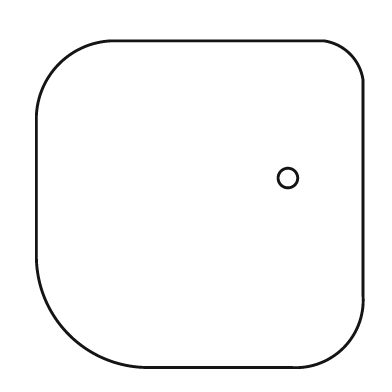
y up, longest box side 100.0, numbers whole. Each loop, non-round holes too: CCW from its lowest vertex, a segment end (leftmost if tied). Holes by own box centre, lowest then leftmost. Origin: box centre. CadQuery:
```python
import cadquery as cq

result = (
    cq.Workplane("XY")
    .moveTo(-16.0, -50.0)
    .lineTo(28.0, -50.0)
    .threePointArc((44.0, -44.0), (50.0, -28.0))
    .lineTo(50.0, 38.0)
    .threePointArc((46.0, 46.0), (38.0, 50.0))
    .lineTo(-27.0, 50.0)
    .threePointArc((-43.0, 43.0), (-50.0, 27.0))
    .lineTo(-50.0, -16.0)
    .threePointArc((-40.0, -40.0), (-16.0, -50.0))
    .close()
    .moveTo(27.0, 8.0)
    .circle(3.0)
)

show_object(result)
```